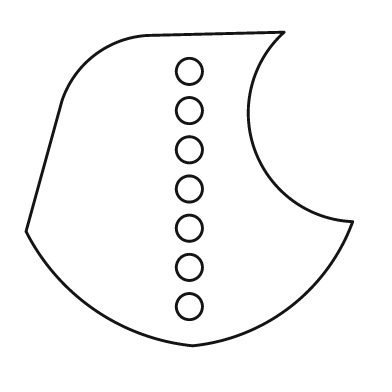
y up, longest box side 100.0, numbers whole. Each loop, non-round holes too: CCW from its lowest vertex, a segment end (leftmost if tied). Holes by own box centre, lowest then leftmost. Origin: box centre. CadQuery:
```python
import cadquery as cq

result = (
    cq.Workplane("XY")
    .moveTo(1.0, -48.0)
    .threePointArc((31.0, -36.0), (50.0, -10.0))
    .threePointArc((20.0, 12.0), (29.0, 48.0))
    .lineTo(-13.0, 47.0)
    .threePointArc((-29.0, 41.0), (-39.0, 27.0))
    .lineTo(-50.0, -13.0)
    .threePointArc((-29.0, -37.0), (1.0, -48.0))
    .close()
    .moveTo(0.0, -36.0)
    .circle(4.0)
    .moveTo(0.0, -24.0)
    .circle(4.0)
    .moveTo(0.0, -12.0)
    .circle(4.0)
    .moveTo(0.0, 0.0)
    .circle(4.0)
    .moveTo(0.0, 12.0)
    .circle(4.0)
    .moveTo(0.0, 24.0)
    .circle(4.0)
    .moveTo(0.0, 36.0)
    .circle(4.0)
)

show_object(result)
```